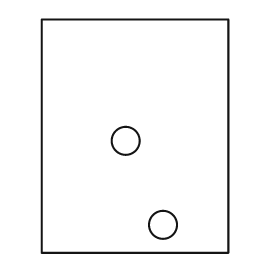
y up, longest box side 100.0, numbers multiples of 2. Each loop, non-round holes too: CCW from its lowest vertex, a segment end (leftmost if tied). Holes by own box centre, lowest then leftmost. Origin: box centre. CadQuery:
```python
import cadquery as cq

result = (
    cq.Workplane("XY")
    .moveTo(-40.0, -50.0)
    .lineTo(40.0, -50.0)
    .lineTo(40.0, 50.0)
    .lineTo(-40.0, 50.0)
    .close()
    .moveTo(12.0, -38.0)
    .circle(6.0)
    .moveTo(-4.0, -2.0)
    .circle(6.0)
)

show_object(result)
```